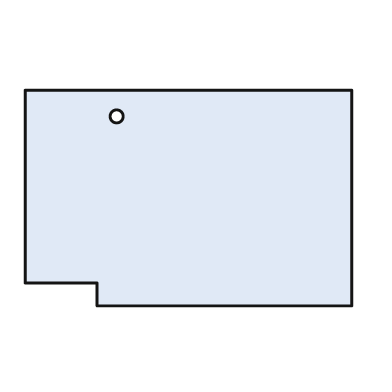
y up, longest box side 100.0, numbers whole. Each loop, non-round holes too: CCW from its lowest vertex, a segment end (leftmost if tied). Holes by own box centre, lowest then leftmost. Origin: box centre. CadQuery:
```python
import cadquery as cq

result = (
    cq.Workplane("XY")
    .moveTo(-28.0, -33.0)
    .lineTo(50.0, -33.0)
    .lineTo(50.0, 33.0)
    .lineTo(-50.0, 33.0)
    .lineTo(-50.0, -26.0)
    .lineTo(-28.0, -26.0)
    .close()
    .moveTo(-22.0, 25.0)
    .circle(2.0)
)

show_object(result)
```